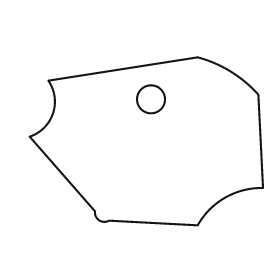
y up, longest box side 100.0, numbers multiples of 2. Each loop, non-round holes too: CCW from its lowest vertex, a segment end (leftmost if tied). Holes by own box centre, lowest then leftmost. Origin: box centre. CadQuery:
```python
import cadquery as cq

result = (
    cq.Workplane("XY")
    .moveTo(22.0, -36.0)
    .threePointArc((34.0, -24.0), (50.0, -20.0))
    .lineTo(48.0, 20.0)
    .threePointArc((36.0, 30.0), (22.0, 36.0))
    .lineTo(-42.0, 26.0)
    .threePointArc((-40.0, 12.0), (-50.0, 2.0))
    .lineTo(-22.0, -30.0)
    .threePointArc((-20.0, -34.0), (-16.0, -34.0))
    .close()
    .moveTo(2.0, 18.0)
    .circle(6.0)
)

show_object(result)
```